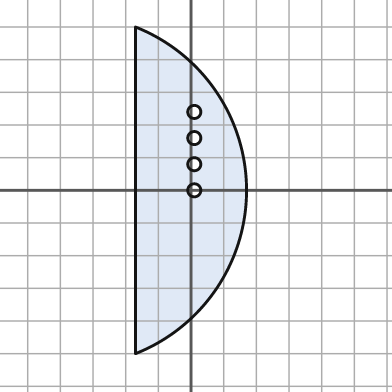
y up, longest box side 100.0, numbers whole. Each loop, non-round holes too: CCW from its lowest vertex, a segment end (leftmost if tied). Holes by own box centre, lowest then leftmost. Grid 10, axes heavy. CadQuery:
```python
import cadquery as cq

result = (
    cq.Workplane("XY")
    .moveTo(-17.0, -50.0)
    .threePointArc((17.0, 0.0), (-17.0, 50.0))
    .close()
    .moveTo(1.0, 0.0)
    .circle(2.0)
    .moveTo(1.0, 8.0)
    .circle(2.0)
    .moveTo(1.0, 16.0)
    .circle(2.0)
    .moveTo(1.0, 24.0)
    .circle(2.0)
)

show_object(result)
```